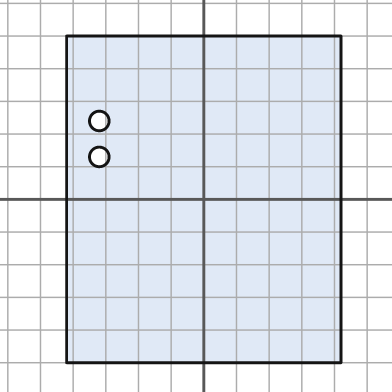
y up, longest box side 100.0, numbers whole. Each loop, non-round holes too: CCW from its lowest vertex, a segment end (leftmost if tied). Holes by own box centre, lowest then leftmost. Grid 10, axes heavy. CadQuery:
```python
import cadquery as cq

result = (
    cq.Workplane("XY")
    .moveTo(-42.0, -50.0)
    .lineTo(42.0, -50.0)
    .lineTo(42.0, 50.0)
    .lineTo(-42.0, 50.0)
    .close()
    .moveTo(-32.0, 13.0)
    .circle(3.0)
    .moveTo(-32.0, 24.0)
    .circle(3.0)
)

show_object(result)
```